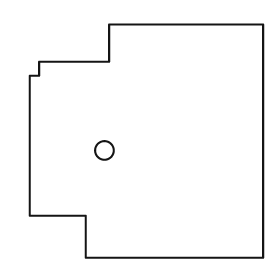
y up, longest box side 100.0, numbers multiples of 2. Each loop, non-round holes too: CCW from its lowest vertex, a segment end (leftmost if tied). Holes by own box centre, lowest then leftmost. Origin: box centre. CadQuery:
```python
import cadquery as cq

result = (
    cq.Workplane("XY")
    .moveTo(-26.0, -50.0)
    .lineTo(50.0, -50.0)
    .lineTo(50.0, 50.0)
    .lineTo(-16.0, 50.0)
    .lineTo(-16.0, 34.0)
    .lineTo(-46.0, 34.0)
    .lineTo(-46.0, 28.0)
    .lineTo(-50.0, 28.0)
    .lineTo(-50.0, -32.0)
    .lineTo(-26.0, -32.0)
    .close()
    .moveTo(-18.0, -4.0)
    .circle(4.0)
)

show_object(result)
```